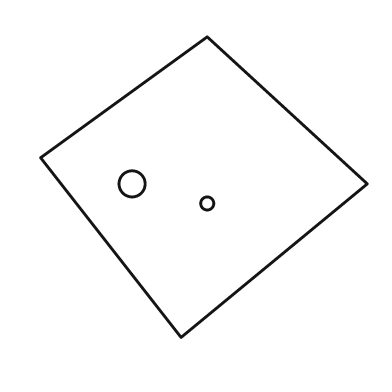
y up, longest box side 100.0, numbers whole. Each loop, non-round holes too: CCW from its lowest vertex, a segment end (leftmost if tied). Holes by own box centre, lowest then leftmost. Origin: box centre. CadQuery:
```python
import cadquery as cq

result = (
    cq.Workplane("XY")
    .moveTo(-7.0, -46.0)
    .lineTo(50.0, 1.0)
    .lineTo(1.0, 46.0)
    .lineTo(-50.0, 9.0)
    .close()
    .moveTo(1.0, -5.0)
    .circle(2.0)
    .moveTo(-22.0, 1.0)
    .circle(4.0)
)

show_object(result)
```